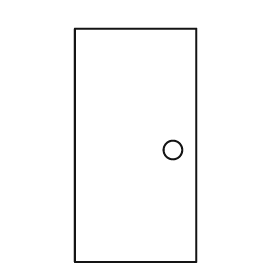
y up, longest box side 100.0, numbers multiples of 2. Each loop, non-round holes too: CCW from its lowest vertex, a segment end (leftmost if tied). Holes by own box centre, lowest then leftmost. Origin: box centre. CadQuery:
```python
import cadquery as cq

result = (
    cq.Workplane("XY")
    .moveTo(-26.0, -50.0)
    .lineTo(26.0, -50.0)
    .lineTo(26.0, 50.0)
    .lineTo(-26.0, 50.0)
    .close()
    .moveTo(16.0, -2.0)
    .circle(4.0)
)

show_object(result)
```